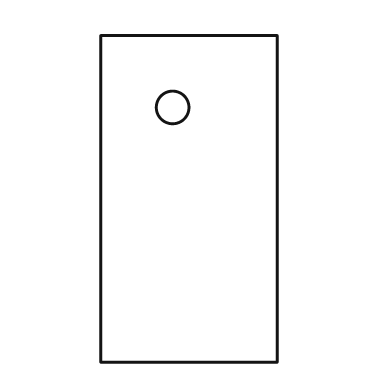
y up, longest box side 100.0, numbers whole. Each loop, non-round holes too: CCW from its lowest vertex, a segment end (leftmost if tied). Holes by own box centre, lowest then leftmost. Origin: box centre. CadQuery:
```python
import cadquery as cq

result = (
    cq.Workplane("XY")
    .moveTo(-27.0, -50.0)
    .lineTo(27.0, -50.0)
    .lineTo(27.0, 50.0)
    .lineTo(-27.0, 50.0)
    .close()
    .moveTo(-5.0, 28.0)
    .circle(5.0)
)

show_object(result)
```